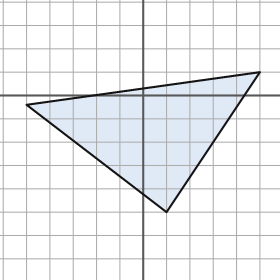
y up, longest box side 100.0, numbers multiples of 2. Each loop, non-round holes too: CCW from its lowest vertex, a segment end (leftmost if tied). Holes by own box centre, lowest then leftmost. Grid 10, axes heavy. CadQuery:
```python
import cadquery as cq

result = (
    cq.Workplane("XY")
    .moveTo(10.0, -50.0)
    .lineTo(50.0, 10.0)
    .lineTo(-50.0, -4.0)
    .close()
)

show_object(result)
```